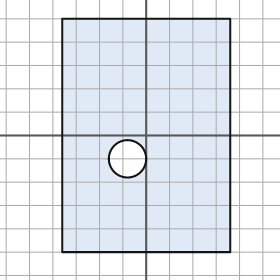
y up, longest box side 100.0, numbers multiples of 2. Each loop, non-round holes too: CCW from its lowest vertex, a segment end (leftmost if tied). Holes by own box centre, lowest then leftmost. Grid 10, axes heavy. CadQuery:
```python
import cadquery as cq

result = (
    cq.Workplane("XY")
    .moveTo(-36.0, -50.0)
    .lineTo(36.0, -50.0)
    .lineTo(36.0, 50.0)
    .lineTo(-36.0, 50.0)
    .close()
    .moveTo(-8.0, -10.0)
    .circle(8.0)
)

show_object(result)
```